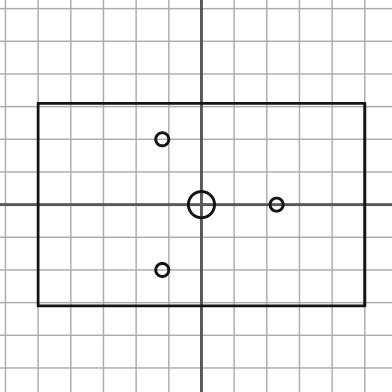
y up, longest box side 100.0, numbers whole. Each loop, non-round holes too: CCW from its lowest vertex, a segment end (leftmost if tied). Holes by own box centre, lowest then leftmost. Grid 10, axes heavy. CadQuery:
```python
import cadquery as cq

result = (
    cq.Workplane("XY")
    .moveTo(-50.0, -31.0)
    .lineTo(50.0, -31.0)
    .lineTo(50.0, 31.0)
    .lineTo(-50.0, 31.0)
    .close()
    .moveTo(-12.0, -20.0)
    .circle(2.0)
    .moveTo(0.0, 0.0)
    .circle(4.0)
    .moveTo(23.0, 0.0)
    .circle(2.0)
    .moveTo(-12.0, 20.0)
    .circle(2.0)
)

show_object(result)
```